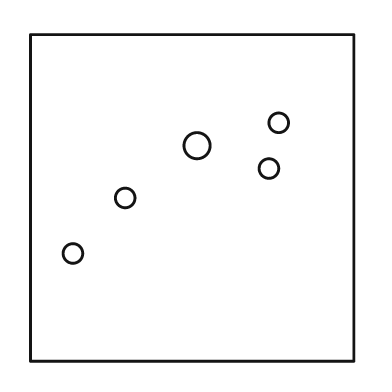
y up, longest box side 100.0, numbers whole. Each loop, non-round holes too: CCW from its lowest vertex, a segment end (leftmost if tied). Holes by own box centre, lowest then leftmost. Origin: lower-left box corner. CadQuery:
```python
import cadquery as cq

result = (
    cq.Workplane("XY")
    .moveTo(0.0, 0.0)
    .lineTo(99.0, 0.0)
    .lineTo(99.0, 100.0)
    .lineTo(0.0, 100.0)
    .close()
    .moveTo(13.0, 33.0)
    .circle(3.0)
    .moveTo(29.0, 50.0)
    .circle(3.0)
    .moveTo(73.0, 59.0)
    .circle(3.0)
    .moveTo(51.0, 66.0)
    .circle(4.0)
    .moveTo(76.0, 73.0)
    .circle(3.0)
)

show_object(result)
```